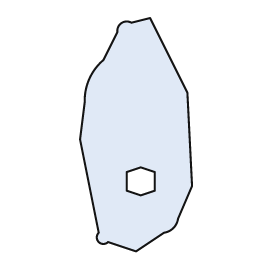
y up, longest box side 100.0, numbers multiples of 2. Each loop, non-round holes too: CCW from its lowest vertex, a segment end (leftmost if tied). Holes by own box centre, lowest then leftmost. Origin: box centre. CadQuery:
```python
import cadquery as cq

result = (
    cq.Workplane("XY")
    .moveTo(0.0, -50.0)
    .lineTo(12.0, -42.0)
    .threePointArc((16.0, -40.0), (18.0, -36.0))
    .lineTo(24.0, -22.0)
    .lineTo(22.0, 18.0)
    .lineTo(6.0, 50.0)
    .lineTo(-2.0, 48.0)
    .threePointArc((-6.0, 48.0), (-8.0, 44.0))
    .lineTo(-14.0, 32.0)
    .threePointArc((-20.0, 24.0), (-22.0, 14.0))
    .lineTo(-24.0, -2.0)
    .lineTo(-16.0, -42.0)
    .threePointArc((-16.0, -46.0), (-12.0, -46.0))
    .close()
    .moveTo(2.0, -26.0)
    .lineTo(8.0, -24.0)
    .lineTo(8.0, -16.0)
    .lineTo(2.0, -14.0)
    .lineTo(-4.0, -16.0)
    .lineTo(-4.0, -24.0)
    .close()
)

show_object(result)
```